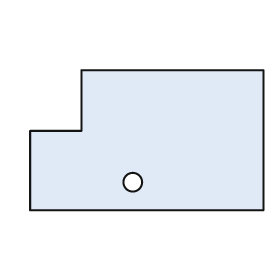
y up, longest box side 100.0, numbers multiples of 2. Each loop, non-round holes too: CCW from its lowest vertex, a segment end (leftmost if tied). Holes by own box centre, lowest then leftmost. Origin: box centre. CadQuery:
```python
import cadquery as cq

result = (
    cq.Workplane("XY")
    .moveTo(-50.0, -30.0)
    .lineTo(50.0, -30.0)
    .lineTo(50.0, 30.0)
    .lineTo(-28.0, 30.0)
    .lineTo(-28.0, 4.0)
    .lineTo(-50.0, 4.0)
    .close()
    .moveTo(-6.0, -18.0)
    .circle(4.0)
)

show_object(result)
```